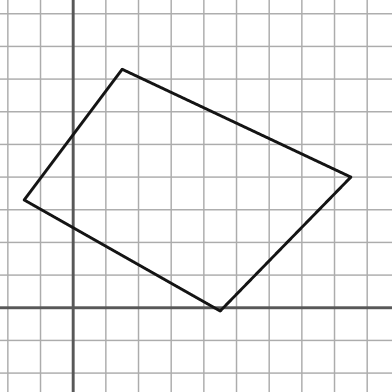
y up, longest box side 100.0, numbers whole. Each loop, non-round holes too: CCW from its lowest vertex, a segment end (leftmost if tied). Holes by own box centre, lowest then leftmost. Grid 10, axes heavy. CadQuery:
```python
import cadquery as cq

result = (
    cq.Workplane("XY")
    .moveTo(45.0, -1.0)
    .lineTo(85.0, 40.0)
    .lineTo(15.0, 73.0)
    .lineTo(-15.0, 33.0)
    .close()
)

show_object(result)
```